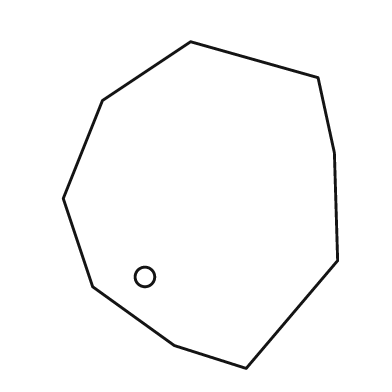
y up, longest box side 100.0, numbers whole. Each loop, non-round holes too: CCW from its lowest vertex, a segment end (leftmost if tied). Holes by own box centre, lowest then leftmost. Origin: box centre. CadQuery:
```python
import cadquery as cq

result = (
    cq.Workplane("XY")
    .moveTo(14.0, -50.0)
    .lineTo(42.0, -17.0)
    .lineTo(41.0, 16.0)
    .lineTo(36.0, 39.0)
    .lineTo(-3.0, 50.0)
    .lineTo(-30.0, 32.0)
    .lineTo(-42.0, 2.0)
    .lineTo(-33.0, -25.0)
    .lineTo(-8.0, -43.0)
    .close()
    .moveTo(-17.0, -22.0)
    .circle(3.0)
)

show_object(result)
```